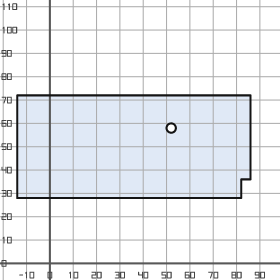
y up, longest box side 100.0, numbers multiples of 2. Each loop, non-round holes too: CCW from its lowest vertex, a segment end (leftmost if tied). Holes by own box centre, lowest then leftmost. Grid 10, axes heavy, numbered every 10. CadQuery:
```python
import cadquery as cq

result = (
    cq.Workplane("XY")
    .moveTo(-14.0, 28.0)
    .lineTo(82.0, 28.0)
    .lineTo(82.0, 36.0)
    .lineTo(86.0, 36.0)
    .lineTo(86.0, 72.0)
    .lineTo(-14.0, 72.0)
    .close()
    .moveTo(52.0, 58.0)
    .circle(2.0)
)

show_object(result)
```